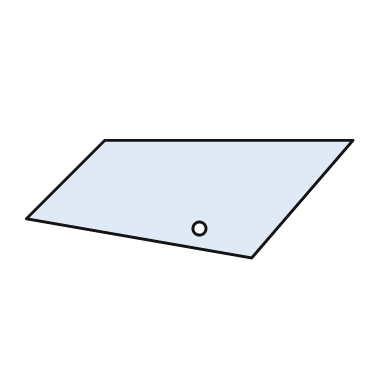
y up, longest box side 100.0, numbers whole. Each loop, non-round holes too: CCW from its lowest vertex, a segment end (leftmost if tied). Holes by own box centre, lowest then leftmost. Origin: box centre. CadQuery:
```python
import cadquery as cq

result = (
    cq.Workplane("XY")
    .moveTo(19.0, -18.0)
    .lineTo(50.0, 18.0)
    .lineTo(-26.0, 18.0)
    .lineTo(-50.0, -6.0)
    .close()
    .moveTo(3.0, -9.0)
    .circle(2.0)
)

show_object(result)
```